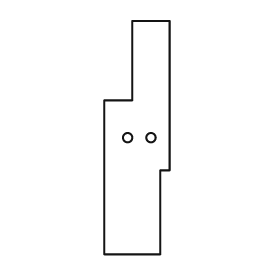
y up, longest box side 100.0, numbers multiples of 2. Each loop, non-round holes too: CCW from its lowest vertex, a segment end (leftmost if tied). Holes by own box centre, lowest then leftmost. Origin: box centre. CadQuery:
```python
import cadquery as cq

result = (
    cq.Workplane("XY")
    .moveTo(-14.0, -50.0)
    .lineTo(10.0, -50.0)
    .lineTo(10.0, -14.0)
    .lineTo(14.0, -14.0)
    .lineTo(14.0, 50.0)
    .lineTo(-2.0, 50.0)
    .lineTo(-2.0, 16.0)
    .lineTo(-14.0, 16.0)
    .close()
    .moveTo(-4.0, 0.0)
    .circle(2.0)
    .moveTo(6.0, 0.0)
    .circle(2.0)
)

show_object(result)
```